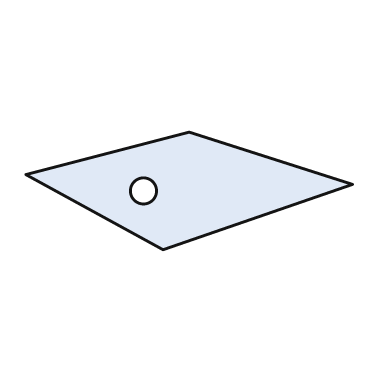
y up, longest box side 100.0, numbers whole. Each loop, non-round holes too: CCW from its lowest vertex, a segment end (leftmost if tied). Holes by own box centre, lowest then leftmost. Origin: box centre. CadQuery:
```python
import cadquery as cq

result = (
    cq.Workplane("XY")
    .moveTo(-8.0, -18.0)
    .lineTo(50.0, 2.0)
    .lineTo(0.0, 18.0)
    .lineTo(-50.0, 5.0)
    .close()
    .moveTo(-14.0, 0.0)
    .circle(4.0)
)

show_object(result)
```